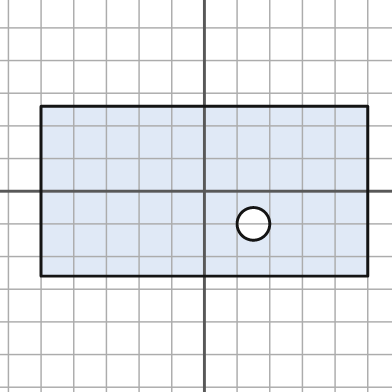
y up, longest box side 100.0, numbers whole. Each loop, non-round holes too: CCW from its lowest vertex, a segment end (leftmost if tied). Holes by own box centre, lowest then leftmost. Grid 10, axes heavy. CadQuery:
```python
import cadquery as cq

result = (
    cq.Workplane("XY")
    .moveTo(-50.0, -26.0)
    .lineTo(50.0, -26.0)
    .lineTo(50.0, 26.0)
    .lineTo(-50.0, 26.0)
    .close()
    .moveTo(15.0, -10.0)
    .circle(5.0)
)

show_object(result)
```